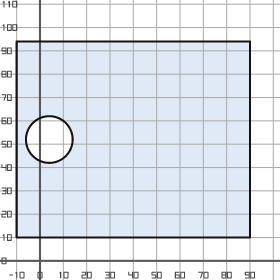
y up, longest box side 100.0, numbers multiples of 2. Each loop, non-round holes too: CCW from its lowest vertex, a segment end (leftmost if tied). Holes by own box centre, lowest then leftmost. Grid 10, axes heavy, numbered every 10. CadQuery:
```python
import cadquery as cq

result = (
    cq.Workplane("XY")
    .moveTo(-10.0, 10.0)
    .lineTo(90.0, 10.0)
    .lineTo(90.0, 94.0)
    .lineTo(-10.0, 94.0)
    .close()
    .moveTo(4.0, 52.0)
    .circle(10.0)
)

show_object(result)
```